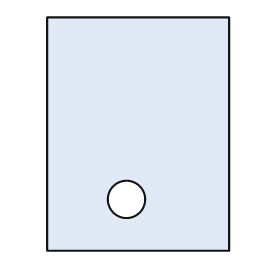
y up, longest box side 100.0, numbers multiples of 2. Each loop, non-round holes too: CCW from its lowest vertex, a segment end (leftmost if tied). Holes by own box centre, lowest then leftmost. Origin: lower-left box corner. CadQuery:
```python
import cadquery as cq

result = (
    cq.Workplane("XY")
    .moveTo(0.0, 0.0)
    .lineTo(78.0, 0.0)
    .lineTo(78.0, 100.0)
    .lineTo(0.0, 100.0)
    .close()
    .moveTo(34.0, 22.0)
    .circle(8.0)
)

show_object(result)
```